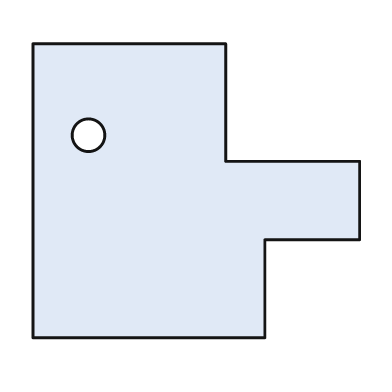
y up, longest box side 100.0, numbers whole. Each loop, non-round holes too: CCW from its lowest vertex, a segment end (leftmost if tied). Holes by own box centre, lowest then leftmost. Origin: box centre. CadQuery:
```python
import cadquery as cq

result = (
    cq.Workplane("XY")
    .moveTo(-50.0, -45.0)
    .lineTo(21.0, -45.0)
    .lineTo(21.0, -15.0)
    .lineTo(50.0, -15.0)
    .lineTo(50.0, 9.0)
    .lineTo(9.0, 9.0)
    .lineTo(9.0, 45.0)
    .lineTo(-50.0, 45.0)
    .close()
    .moveTo(-33.0, 17.0)
    .circle(5.0)
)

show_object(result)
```